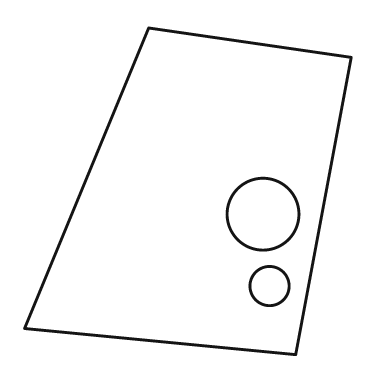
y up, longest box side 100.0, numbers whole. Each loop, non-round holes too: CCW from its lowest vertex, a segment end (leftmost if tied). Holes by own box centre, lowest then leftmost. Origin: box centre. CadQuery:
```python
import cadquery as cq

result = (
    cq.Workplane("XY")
    .moveTo(33.0, -50.0)
    .lineTo(50.0, 41.0)
    .lineTo(-12.0, 50.0)
    .lineTo(-50.0, -42.0)
    .close()
    .moveTo(25.0, -29.0)
    .circle(6.0)
    .moveTo(23.0, -7.0)
    .circle(11.0)
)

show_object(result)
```